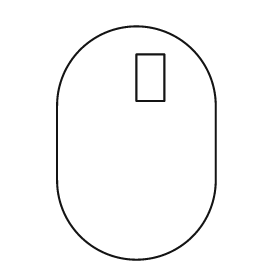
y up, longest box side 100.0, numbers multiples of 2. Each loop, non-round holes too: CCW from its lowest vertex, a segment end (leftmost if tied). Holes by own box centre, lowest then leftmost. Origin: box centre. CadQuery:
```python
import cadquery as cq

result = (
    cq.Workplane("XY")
    .moveTo(-34.0, -16.0)
    .threePointArc((0.0, -50.0), (34.0, -16.0))
    .lineTo(34.0, 16.0)
    .threePointArc((0.0, 50.0), (-34.0, 16.0))
    .close()
    .moveTo(0.0, 18.0)
    .lineTo(12.0, 18.0)
    .lineTo(12.0, 38.0)
    .lineTo(0.0, 38.0)
    .close()
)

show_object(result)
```